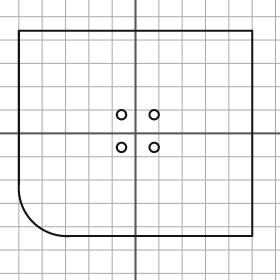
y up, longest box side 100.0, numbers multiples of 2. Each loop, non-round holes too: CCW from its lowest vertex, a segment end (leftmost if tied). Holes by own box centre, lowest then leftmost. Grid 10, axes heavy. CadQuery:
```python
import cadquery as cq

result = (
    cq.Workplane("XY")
    .moveTo(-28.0, -44.0)
    .lineTo(50.0, -44.0)
    .lineTo(50.0, 44.0)
    .lineTo(-50.0, 44.0)
    .lineTo(-50.0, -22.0)
    .threePointArc((-44.0, -38.0), (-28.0, -44.0))
    .close()
    .moveTo(-6.0, -6.0)
    .circle(2.0)
    .moveTo(8.0, -6.0)
    .circle(2.0)
    .moveTo(-6.0, 8.0)
    .circle(2.0)
    .moveTo(8.0, 8.0)
    .circle(2.0)
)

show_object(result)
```